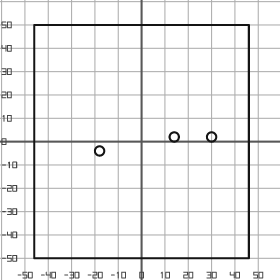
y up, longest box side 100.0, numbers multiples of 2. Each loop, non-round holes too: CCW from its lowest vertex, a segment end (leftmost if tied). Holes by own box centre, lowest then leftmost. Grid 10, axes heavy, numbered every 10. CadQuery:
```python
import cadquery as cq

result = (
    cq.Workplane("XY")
    .moveTo(-46.0, -50.0)
    .lineTo(46.0, -50.0)
    .lineTo(46.0, 50.0)
    .lineTo(-46.0, 50.0)
    .close()
    .moveTo(-18.0, -4.0)
    .circle(2.0)
    .moveTo(14.0, 2.0)
    .circle(2.0)
    .moveTo(30.0, 2.0)
    .circle(2.0)
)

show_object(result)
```